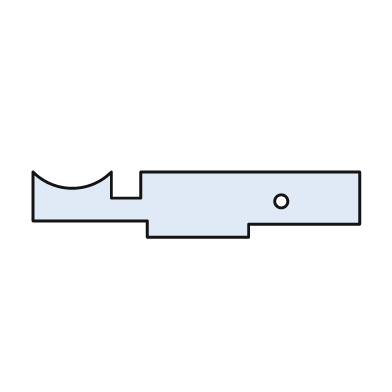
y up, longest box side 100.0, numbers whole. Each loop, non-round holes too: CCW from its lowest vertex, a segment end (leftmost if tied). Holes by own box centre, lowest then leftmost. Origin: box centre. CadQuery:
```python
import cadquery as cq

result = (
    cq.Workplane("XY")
    .moveTo(-15.0, -10.0)
    .lineTo(16.0, -10.0)
    .lineTo(16.0, -6.0)
    .lineTo(50.0, -6.0)
    .lineTo(50.0, 10.0)
    .lineTo(-17.0, 10.0)
    .lineTo(-17.0, 2.0)
    .lineTo(-26.0, 2.0)
    .lineTo(-26.0, 10.0)
    .threePointArc((-38.0, 5.0), (-50.0, 10.0))
    .lineTo(-50.0, -5.0)
    .lineTo(-15.0, -5.0)
    .close()
    .moveTo(26.0, 1.0)
    .circle(2.0)
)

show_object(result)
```